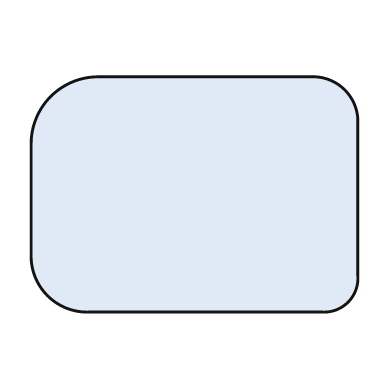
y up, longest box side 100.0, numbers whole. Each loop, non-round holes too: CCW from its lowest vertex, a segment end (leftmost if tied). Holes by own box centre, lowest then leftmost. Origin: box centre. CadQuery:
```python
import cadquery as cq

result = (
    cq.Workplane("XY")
    .moveTo(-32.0, -36.0)
    .lineTo(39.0, -36.0)
    .threePointArc((47.0, -33.0), (50.0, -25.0))
    .lineTo(50.0, 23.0)
    .threePointArc((46.0, 32.0), (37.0, 36.0))
    .lineTo(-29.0, 36.0)
    .threePointArc((-44.0, 30.0), (-50.0, 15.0))
    .lineTo(-50.0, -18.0)
    .threePointArc((-45.0, -31.0), (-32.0, -36.0))
    .close()
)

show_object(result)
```